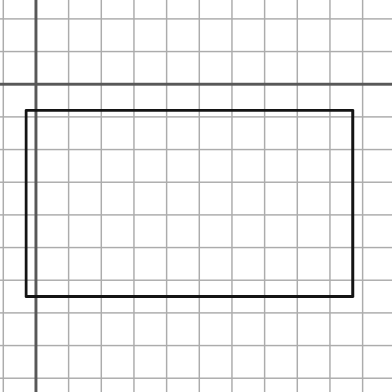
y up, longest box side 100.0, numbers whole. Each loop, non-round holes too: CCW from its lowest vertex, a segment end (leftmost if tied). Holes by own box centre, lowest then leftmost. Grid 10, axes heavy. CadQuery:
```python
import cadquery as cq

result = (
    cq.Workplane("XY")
    .moveTo(-3.0, -65.0)
    .lineTo(97.0, -65.0)
    .lineTo(97.0, -8.0)
    .lineTo(-3.0, -8.0)
    .close()
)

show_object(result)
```